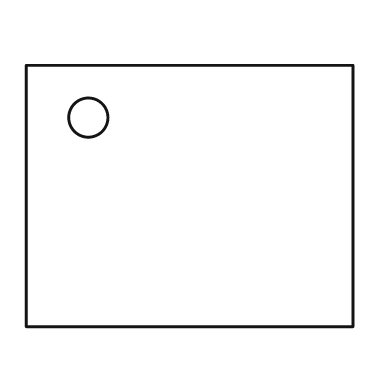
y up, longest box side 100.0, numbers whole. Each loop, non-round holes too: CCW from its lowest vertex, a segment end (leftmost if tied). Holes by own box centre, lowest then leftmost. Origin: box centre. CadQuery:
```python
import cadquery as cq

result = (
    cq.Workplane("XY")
    .moveTo(-50.0, -40.0)
    .lineTo(50.0, -40.0)
    .lineTo(50.0, 40.0)
    .lineTo(-50.0, 40.0)
    .close()
    .moveTo(-31.0, 24.0)
    .circle(6.0)
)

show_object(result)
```